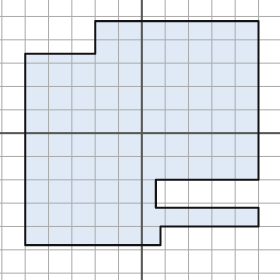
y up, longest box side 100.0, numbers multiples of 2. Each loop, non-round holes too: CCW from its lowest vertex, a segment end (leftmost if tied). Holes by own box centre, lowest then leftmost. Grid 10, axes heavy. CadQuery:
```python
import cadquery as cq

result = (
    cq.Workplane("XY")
    .moveTo(-50.0, -48.0)
    .lineTo(8.0, -48.0)
    .lineTo(8.0, -40.0)
    .lineTo(50.0, -40.0)
    .lineTo(50.0, -32.0)
    .lineTo(6.0, -32.0)
    .lineTo(6.0, -20.0)
    .lineTo(50.0, -20.0)
    .lineTo(50.0, 48.0)
    .lineTo(-20.0, 48.0)
    .lineTo(-20.0, 34.0)
    .lineTo(-50.0, 34.0)
    .close()
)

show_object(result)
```